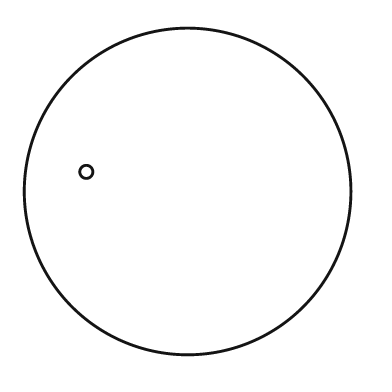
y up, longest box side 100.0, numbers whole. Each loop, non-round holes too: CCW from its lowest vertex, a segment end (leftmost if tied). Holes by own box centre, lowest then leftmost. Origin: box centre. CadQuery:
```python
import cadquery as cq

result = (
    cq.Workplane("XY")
    .moveTo(0.0, 0.0)
    .circle(50.0)
    .moveTo(-31.0, 6.0)
    .circle(2.0)
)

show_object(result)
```